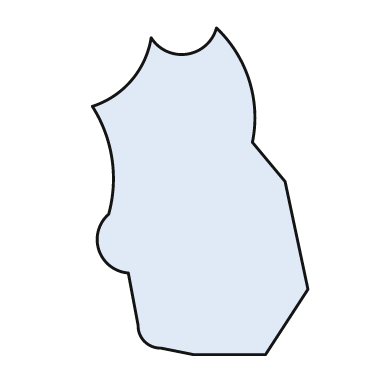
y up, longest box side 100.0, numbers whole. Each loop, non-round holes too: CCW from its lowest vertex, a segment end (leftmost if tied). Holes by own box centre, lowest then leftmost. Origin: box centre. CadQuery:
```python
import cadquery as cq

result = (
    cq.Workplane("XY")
    .moveTo(-2.0, -50.0)
    .lineTo(20.0, -50.0)
    .lineTo(33.0, -30.0)
    .lineTo(26.0, 3.0)
    .lineTo(16.0, 15.0)
    .threePointArc((15.0, 34.0), (5.0, 50.0))
    .threePointArc((-4.0, 42.0), (-15.0, 47.0))
    .threePointArc((-21.0, 34.0), (-33.0, 26.0))
    .threePointArc((-27.0, 10.0), (-28.0, -7.0))
    .threePointArc((-31.0, -18.0), (-22.0, -25.0))
    .lineTo(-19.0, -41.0)
    .threePointArc((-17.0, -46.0), (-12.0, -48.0))
    .close()
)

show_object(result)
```